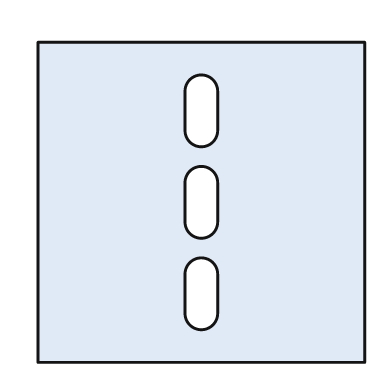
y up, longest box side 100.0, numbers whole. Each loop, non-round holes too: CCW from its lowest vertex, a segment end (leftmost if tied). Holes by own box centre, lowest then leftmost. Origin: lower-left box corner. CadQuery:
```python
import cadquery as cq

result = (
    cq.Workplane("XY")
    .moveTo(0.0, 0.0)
    .lineTo(100.0, 0.0)
    .lineTo(100.0, 98.0)
    .lineTo(0.0, 98.0)
    .close()
    .moveTo(45.0, 15.0)
    .threePointArc((50.0, 10.0), (55.0, 15.0))
    .lineTo(55.0, 27.0)
    .threePointArc((50.0, 32.0), (45.0, 27.0))
    .close()
    .moveTo(45.0, 43.0)
    .threePointArc((50.0, 38.0), (55.0, 43.0))
    .lineTo(55.0, 55.0)
    .threePointArc((50.0, 60.0), (45.0, 55.0))
    .close()
    .moveTo(45.0, 71.0)
    .threePointArc((50.0, 66.0), (55.0, 71.0))
    .lineTo(55.0, 83.0)
    .threePointArc((50.0, 88.0), (45.0, 83.0))
    .close()
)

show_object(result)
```